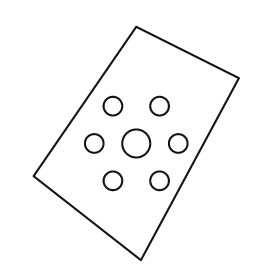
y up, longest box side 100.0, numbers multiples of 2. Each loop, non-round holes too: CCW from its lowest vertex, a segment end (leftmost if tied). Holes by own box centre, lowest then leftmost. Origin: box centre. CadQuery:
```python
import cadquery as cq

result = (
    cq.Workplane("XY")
    .moveTo(2.0, -50.0)
    .lineTo(44.0, 28.0)
    .lineTo(0.0, 50.0)
    .lineTo(-44.0, -14.0)
    .close()
    .moveTo(-10.0, -16.0)
    .circle(4.0)
    .moveTo(10.0, -16.0)
    .circle(4.0)
    .moveTo(-18.0, 0.0)
    .circle(4.0)
    .moveTo(0.0, 0.0)
    .circle(6.0)
    .moveTo(18.0, 0.0)
    .circle(4.0)
    .moveTo(-10.0, 16.0)
    .circle(4.0)
    .moveTo(10.0, 16.0)
    .circle(4.0)
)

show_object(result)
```